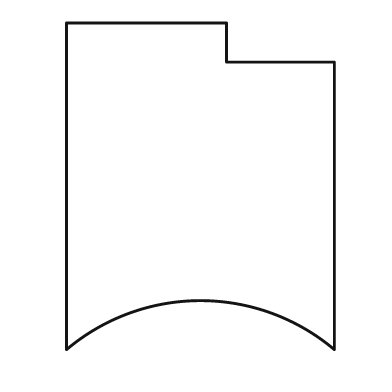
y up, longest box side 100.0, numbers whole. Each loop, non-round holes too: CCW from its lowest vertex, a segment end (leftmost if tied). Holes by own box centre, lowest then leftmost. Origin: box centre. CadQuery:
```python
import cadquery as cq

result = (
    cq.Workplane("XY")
    .moveTo(-41.0, -50.0)
    .threePointArc((0.0, -35.0), (41.0, -50.0))
    .lineTo(41.0, 38.0)
    .lineTo(8.0, 38.0)
    .lineTo(8.0, 50.0)
    .lineTo(-41.0, 50.0)
    .close()
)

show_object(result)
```